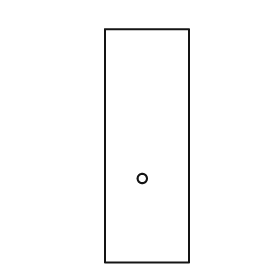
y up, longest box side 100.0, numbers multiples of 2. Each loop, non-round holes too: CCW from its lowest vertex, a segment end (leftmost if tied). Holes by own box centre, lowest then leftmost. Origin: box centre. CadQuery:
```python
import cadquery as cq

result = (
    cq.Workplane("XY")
    .moveTo(-18.0, -50.0)
    .lineTo(18.0, -50.0)
    .lineTo(18.0, 50.0)
    .lineTo(-18.0, 50.0)
    .close()
    .moveTo(-2.0, -14.0)
    .circle(2.0)
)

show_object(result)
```